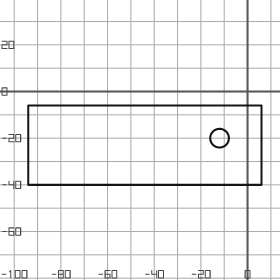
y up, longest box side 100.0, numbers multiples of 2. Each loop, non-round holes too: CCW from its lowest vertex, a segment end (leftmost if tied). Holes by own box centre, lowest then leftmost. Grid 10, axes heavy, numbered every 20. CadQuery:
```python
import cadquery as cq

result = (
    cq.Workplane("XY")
    .moveTo(-94.0, -40.0)
    .lineTo(6.0, -40.0)
    .lineTo(6.0, -6.0)
    .lineTo(-94.0, -6.0)
    .close()
    .moveTo(-12.0, -20.0)
    .circle(4.0)
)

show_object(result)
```